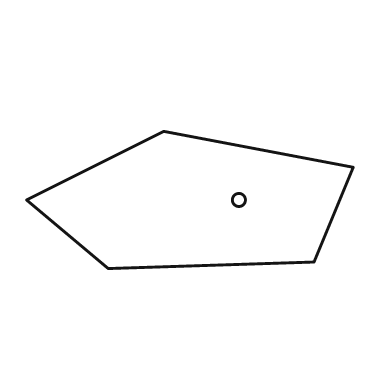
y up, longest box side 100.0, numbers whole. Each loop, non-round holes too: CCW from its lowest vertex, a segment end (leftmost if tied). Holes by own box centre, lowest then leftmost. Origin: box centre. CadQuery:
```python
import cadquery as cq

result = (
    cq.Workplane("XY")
    .moveTo(-25.0, -21.0)
    .lineTo(38.0, -19.0)
    .lineTo(50.0, 10.0)
    .lineTo(-8.0, 21.0)
    .lineTo(-50.0, 0.0)
    .close()
    .moveTo(15.0, 0.0)
    .circle(2.0)
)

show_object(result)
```